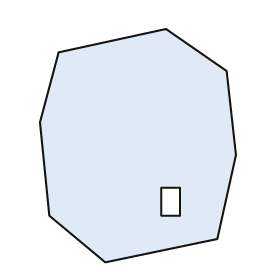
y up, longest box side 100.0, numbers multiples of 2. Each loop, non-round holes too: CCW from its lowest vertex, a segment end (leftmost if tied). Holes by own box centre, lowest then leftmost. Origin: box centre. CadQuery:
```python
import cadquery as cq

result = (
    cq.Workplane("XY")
    .moveTo(-14.0, -50.0)
    .lineTo(34.0, -40.0)
    .lineTo(42.0, -4.0)
    .lineTo(38.0, 32.0)
    .lineTo(12.0, 50.0)
    .lineTo(-34.0, 40.0)
    .lineTo(-42.0, 10.0)
    .lineTo(-38.0, -30.0)
    .close()
    .moveTo(10.0, -30.0)
    .lineTo(18.0, -30.0)
    .lineTo(18.0, -18.0)
    .lineTo(10.0, -18.0)
    .close()
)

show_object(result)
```